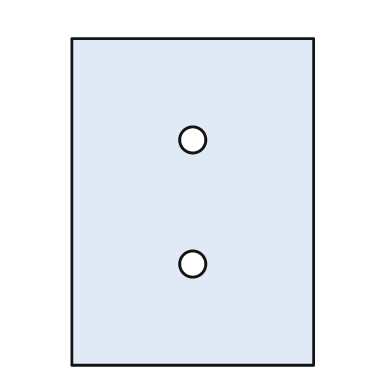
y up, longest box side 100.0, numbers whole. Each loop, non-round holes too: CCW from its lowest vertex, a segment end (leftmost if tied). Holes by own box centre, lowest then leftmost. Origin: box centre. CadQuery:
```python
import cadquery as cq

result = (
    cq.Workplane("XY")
    .moveTo(-37.0, -50.0)
    .lineTo(37.0, -50.0)
    .lineTo(37.0, 50.0)
    .lineTo(-37.0, 50.0)
    .close()
    .moveTo(0.0, -19.0)
    .circle(4.0)
    .moveTo(0.0, 19.0)
    .circle(4.0)
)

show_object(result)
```